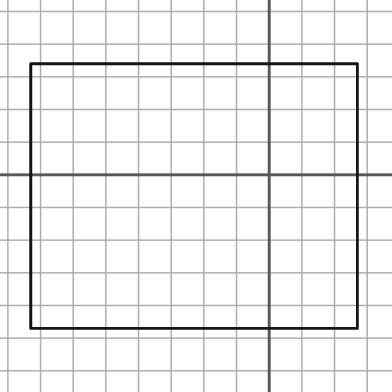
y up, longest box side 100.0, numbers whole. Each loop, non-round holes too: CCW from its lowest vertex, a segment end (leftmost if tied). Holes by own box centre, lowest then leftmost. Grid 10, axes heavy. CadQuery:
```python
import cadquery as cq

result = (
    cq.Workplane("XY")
    .moveTo(-73.0, -47.0)
    .lineTo(27.0, -47.0)
    .lineTo(27.0, 34.0)
    .lineTo(-73.0, 34.0)
    .close()
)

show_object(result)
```